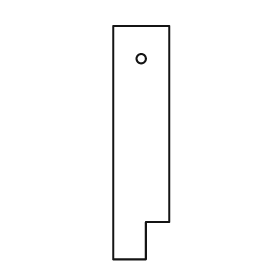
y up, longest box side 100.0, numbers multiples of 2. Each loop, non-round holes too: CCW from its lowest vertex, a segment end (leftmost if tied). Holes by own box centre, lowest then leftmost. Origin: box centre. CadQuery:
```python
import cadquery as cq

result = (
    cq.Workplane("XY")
    .moveTo(-12.0, -50.0)
    .lineTo(2.0, -50.0)
    .lineTo(2.0, -34.0)
    .lineTo(12.0, -34.0)
    .lineTo(12.0, 50.0)
    .lineTo(-12.0, 50.0)
    .close()
    .moveTo(0.0, 36.0)
    .circle(2.0)
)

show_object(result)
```